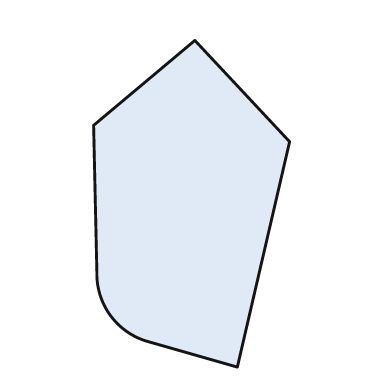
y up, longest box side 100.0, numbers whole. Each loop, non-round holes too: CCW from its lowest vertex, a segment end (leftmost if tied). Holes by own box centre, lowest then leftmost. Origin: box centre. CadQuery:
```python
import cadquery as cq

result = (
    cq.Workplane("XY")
    .moveTo(14.0, -50.0)
    .lineTo(30.0, 19.0)
    .lineTo(1.0, 50.0)
    .lineTo(-30.0, 24.0)
    .lineTo(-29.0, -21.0)
    .threePointArc((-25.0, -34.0), (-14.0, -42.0))
    .close()
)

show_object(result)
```